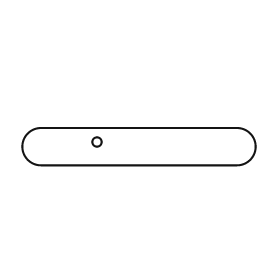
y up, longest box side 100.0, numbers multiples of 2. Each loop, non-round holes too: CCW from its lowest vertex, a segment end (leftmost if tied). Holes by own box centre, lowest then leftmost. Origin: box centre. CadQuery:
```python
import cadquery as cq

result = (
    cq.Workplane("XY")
    .moveTo(-42.0, -8.0)
    .lineTo(42.0, -8.0)
    .threePointArc((50.0, 0.0), (42.0, 8.0))
    .lineTo(-42.0, 8.0)
    .threePointArc((-50.0, 0.0), (-42.0, -8.0))
    .close()
    .moveTo(-18.0, 2.0)
    .circle(2.0)
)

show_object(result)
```